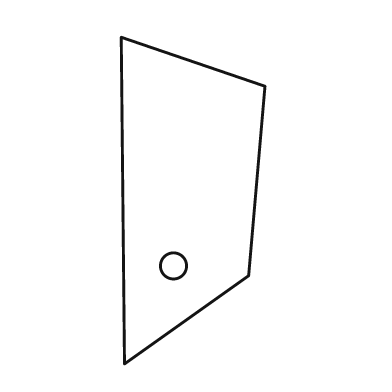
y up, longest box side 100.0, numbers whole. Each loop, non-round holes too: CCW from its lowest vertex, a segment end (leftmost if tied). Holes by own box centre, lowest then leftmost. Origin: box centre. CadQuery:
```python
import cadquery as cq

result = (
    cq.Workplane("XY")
    .moveTo(-21.0, -50.0)
    .lineTo(17.0, -23.0)
    .lineTo(22.0, 35.0)
    .lineTo(-22.0, 50.0)
    .close()
    .moveTo(-6.0, -20.0)
    .circle(4.0)
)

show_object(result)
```